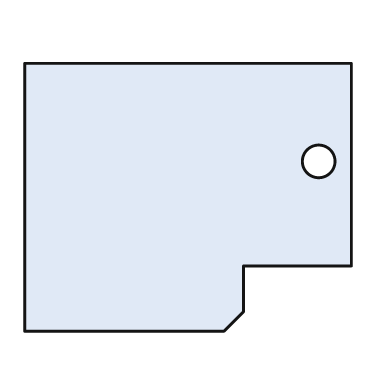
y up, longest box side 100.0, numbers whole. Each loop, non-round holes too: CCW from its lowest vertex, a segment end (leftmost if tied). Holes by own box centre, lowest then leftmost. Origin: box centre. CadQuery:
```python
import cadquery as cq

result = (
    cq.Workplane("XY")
    .moveTo(-50.0, -41.0)
    .lineTo(11.0, -41.0)
    .lineTo(17.0, -35.0)
    .lineTo(17.0, -21.0)
    .lineTo(50.0, -21.0)
    .lineTo(50.0, 41.0)
    .lineTo(-50.0, 41.0)
    .close()
    .moveTo(40.0, 11.0)
    .circle(5.0)
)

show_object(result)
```